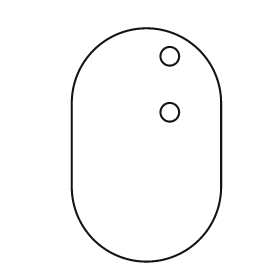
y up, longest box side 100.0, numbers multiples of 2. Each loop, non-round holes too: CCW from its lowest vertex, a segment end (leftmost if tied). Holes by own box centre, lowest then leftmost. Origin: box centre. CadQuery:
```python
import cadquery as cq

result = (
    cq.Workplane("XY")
    .moveTo(-32.0, -18.0)
    .threePointArc((0.0, -50.0), (32.0, -18.0))
    .lineTo(32.0, 18.0)
    .threePointArc((0.0, 50.0), (-32.0, 18.0))
    .close()
    .moveTo(10.0, 14.0)
    .circle(4.0)
    .moveTo(10.0, 38.0)
    .circle(4.0)
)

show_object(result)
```